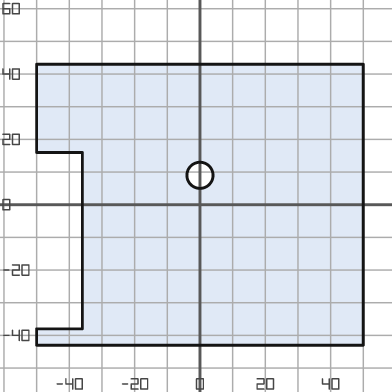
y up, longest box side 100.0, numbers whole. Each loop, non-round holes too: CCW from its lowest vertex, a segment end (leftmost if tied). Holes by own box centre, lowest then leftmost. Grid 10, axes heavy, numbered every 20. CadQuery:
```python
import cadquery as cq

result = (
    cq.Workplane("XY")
    .moveTo(-50.0, -43.0)
    .lineTo(50.0, -43.0)
    .lineTo(50.0, 43.0)
    .lineTo(-50.0, 43.0)
    .lineTo(-50.0, 16.0)
    .lineTo(-36.0, 16.0)
    .lineTo(-36.0, -38.0)
    .lineTo(-50.0, -38.0)
    .close()
    .moveTo(0.0, 9.0)
    .circle(4.0)
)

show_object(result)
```